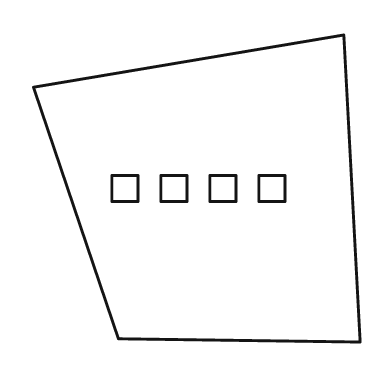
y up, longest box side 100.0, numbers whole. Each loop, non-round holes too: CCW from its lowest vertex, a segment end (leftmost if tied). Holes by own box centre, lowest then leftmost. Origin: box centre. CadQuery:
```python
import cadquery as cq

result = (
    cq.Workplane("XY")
    .moveTo(50.0, -47.0)
    .lineTo(45.0, 47.0)
    .lineTo(-50.0, 31.0)
    .lineTo(-24.0, -46.0)
    .close()
    .moveTo(-26.0, -4.0)
    .lineTo(-18.0, -4.0)
    .lineTo(-18.0, 4.0)
    .lineTo(-26.0, 4.0)
    .close()
    .moveTo(-11.0, -4.0)
    .lineTo(-3.0, -4.0)
    .lineTo(-3.0, 4.0)
    .lineTo(-11.0, 4.0)
    .close()
    .moveTo(4.0, -4.0)
    .lineTo(12.0, -4.0)
    .lineTo(12.0, 4.0)
    .lineTo(4.0, 4.0)
    .close()
    .moveTo(19.0, -4.0)
    .lineTo(27.0, -4.0)
    .lineTo(27.0, 4.0)
    .lineTo(19.0, 4.0)
    .close()
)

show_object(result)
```